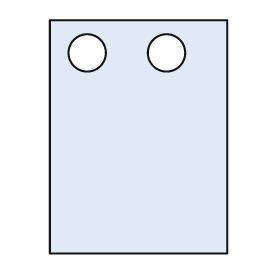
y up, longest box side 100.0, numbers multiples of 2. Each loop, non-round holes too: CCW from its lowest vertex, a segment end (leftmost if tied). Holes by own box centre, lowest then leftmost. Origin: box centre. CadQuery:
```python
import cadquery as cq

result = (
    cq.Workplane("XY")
    .moveTo(-38.0, -50.0)
    .lineTo(38.0, -50.0)
    .lineTo(38.0, 50.0)
    .lineTo(-38.0, 50.0)
    .close()
    .moveTo(-22.0, 36.0)
    .circle(8.0)
    .moveTo(12.0, 36.0)
    .circle(8.0)
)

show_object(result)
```